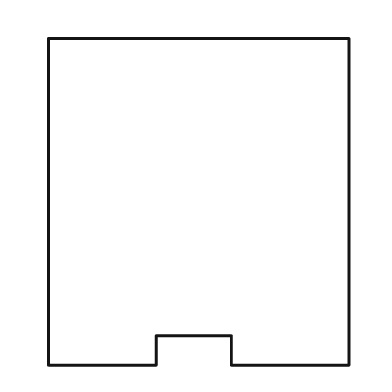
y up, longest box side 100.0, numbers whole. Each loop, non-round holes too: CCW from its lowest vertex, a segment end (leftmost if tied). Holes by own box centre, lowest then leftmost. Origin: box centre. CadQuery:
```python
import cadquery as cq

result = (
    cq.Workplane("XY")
    .moveTo(-46.0, -50.0)
    .lineTo(-13.0, -50.0)
    .lineTo(-13.0, -41.0)
    .lineTo(10.0, -41.0)
    .lineTo(10.0, -50.0)
    .lineTo(46.0, -50.0)
    .lineTo(46.0, 50.0)
    .lineTo(-46.0, 50.0)
    .close()
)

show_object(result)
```